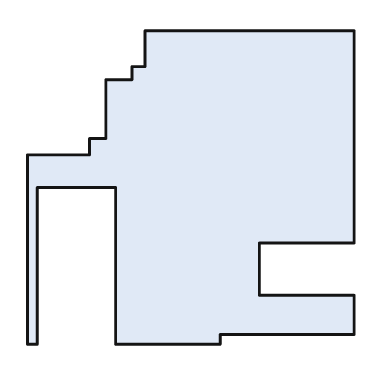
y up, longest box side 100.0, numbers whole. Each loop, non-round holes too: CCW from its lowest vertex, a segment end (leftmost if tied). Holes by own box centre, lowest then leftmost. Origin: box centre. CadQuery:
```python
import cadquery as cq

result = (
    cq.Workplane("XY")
    .moveTo(-50.0, -48.0)
    .lineTo(-47.0, -48.0)
    .lineTo(-47.0, 0.0)
    .lineTo(-23.0, 0.0)
    .lineTo(-23.0, -48.0)
    .lineTo(9.0, -48.0)
    .lineTo(9.0, -45.0)
    .lineTo(50.0, -45.0)
    .lineTo(50.0, -33.0)
    .lineTo(21.0, -33.0)
    .lineTo(21.0, -17.0)
    .lineTo(50.0, -17.0)
    .lineTo(50.0, 48.0)
    .lineTo(-14.0, 48.0)
    .lineTo(-14.0, 37.0)
    .lineTo(-18.0, 37.0)
    .lineTo(-18.0, 33.0)
    .lineTo(-26.0, 33.0)
    .lineTo(-26.0, 15.0)
    .lineTo(-31.0, 15.0)
    .lineTo(-31.0, 10.0)
    .lineTo(-50.0, 10.0)
    .close()
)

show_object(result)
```